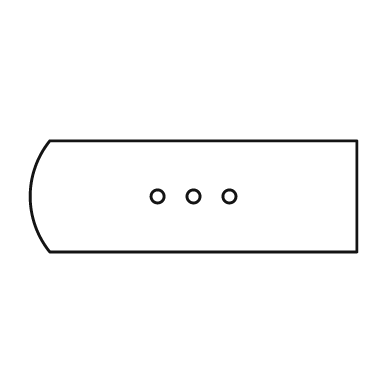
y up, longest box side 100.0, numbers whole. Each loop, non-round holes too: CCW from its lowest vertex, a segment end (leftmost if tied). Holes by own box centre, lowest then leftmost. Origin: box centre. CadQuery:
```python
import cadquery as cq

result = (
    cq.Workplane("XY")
    .moveTo(-44.0, -17.0)
    .lineTo(50.0, -17.0)
    .lineTo(50.0, 17.0)
    .lineTo(-44.0, 17.0)
    .threePointArc((-50.0, 0.0), (-44.0, -17.0))
    .close()
    .moveTo(-11.0, 0.0)
    .circle(2.0)
    .moveTo(0.0, 0.0)
    .circle(2.0)
    .moveTo(11.0, 0.0)
    .circle(2.0)
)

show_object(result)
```